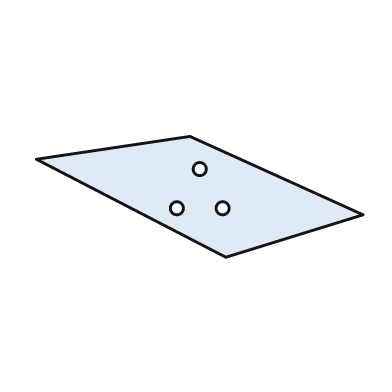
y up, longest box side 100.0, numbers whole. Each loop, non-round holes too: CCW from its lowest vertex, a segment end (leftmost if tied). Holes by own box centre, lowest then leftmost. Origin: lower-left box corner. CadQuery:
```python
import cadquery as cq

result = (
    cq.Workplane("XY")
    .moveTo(58.0, 0.0)
    .lineTo(100.0, 13.0)
    .lineTo(47.0, 37.0)
    .lineTo(0.0, 30.0)
    .close()
    .moveTo(43.0, 15.0)
    .circle(2.0)
    .moveTo(57.0, 15.0)
    .circle(2.0)
    .moveTo(50.0, 27.0)
    .circle(2.0)
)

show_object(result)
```